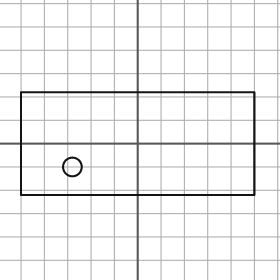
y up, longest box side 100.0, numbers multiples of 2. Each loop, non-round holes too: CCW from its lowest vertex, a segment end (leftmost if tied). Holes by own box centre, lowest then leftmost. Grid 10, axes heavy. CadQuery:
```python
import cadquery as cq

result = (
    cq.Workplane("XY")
    .moveTo(-50.0, -22.0)
    .lineTo(50.0, -22.0)
    .lineTo(50.0, 22.0)
    .lineTo(-50.0, 22.0)
    .close()
    .moveTo(-28.0, -10.0)
    .circle(4.0)
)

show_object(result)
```